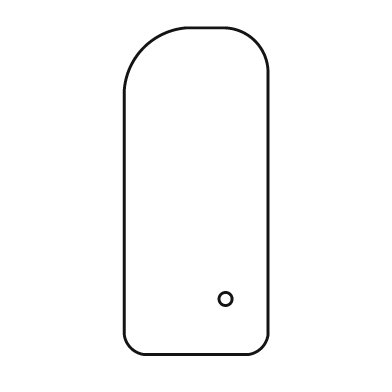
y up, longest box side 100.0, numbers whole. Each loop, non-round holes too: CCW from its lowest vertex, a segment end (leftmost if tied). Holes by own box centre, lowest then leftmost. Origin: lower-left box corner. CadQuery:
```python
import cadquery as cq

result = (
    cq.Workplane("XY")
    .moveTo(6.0, 0.0)
    .lineTo(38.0, 0.0)
    .threePointArc((42.0, 2.0), (44.0, 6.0))
    .lineTo(44.0, 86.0)
    .threePointArc((40.0, 96.0), (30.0, 100.0))
    .lineTo(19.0, 100.0)
    .threePointArc((6.0, 94.0), (0.0, 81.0))
    .lineTo(0.0, 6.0)
    .threePointArc((2.0, 2.0), (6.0, 0.0))
    .close()
    .moveTo(31.0, 17.0)
    .circle(2.0)
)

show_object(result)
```